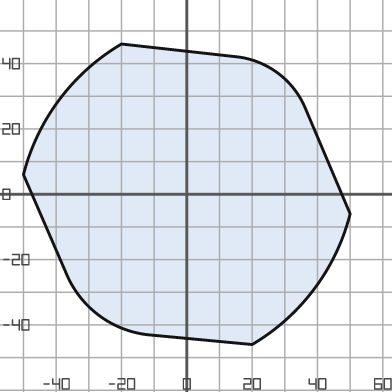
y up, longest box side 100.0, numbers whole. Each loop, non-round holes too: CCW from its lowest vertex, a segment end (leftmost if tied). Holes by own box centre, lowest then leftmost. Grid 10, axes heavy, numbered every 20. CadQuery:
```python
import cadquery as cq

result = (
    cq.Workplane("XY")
    .moveTo(20.0, -46.0)
    .threePointArc((39.0, -29.0), (50.0, -6.0))
    .lineTo(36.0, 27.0)
    .threePointArc((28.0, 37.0), (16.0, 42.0))
    .lineTo(-20.0, 46.0)
    .threePointArc((-39.0, 29.0), (-50.0, 6.0))
    .lineTo(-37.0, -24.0)
    .threePointArc((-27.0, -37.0), (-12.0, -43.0))
    .close()
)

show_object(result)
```